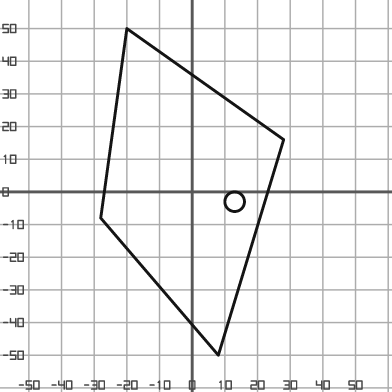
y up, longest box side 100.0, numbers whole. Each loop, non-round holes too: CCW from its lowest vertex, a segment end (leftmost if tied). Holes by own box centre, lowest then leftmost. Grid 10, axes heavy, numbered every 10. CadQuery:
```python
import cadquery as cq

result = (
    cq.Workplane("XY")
    .moveTo(8.0, -50.0)
    .lineTo(28.0, 16.0)
    .lineTo(-20.0, 50.0)
    .lineTo(-28.0, -8.0)
    .close()
    .moveTo(13.0, -3.0)
    .circle(3.0)
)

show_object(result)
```